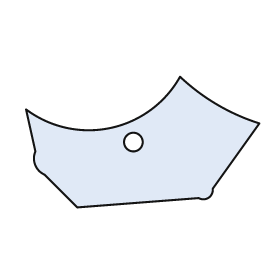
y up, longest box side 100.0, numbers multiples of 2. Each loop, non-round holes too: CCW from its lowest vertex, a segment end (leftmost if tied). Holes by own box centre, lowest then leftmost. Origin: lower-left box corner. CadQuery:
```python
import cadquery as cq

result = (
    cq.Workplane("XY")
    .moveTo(22.0, 0.0)
    .lineTo(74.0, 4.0)
    .threePointArc((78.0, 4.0), (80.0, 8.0))
    .lineTo(100.0, 36.0)
    .threePointArc((82.0, 44.0), (66.0, 56.0))
    .threePointArc((36.0, 34.0), (0.0, 42.0))
    .lineTo(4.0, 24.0)
    .threePointArc((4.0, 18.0), (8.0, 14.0))
    .close()
    .moveTo(46.0, 28.0)
    .circle(4.0)
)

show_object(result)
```